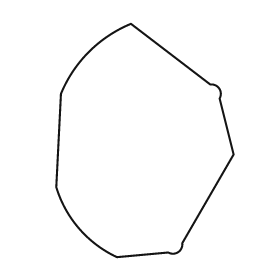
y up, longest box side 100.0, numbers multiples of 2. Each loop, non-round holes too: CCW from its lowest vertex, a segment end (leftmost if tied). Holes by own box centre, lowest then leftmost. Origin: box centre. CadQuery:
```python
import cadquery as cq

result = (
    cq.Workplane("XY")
    .moveTo(-12.0, -50.0)
    .lineTo(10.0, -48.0)
    .threePointArc((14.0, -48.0), (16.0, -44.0))
    .lineTo(38.0, -6.0)
    .lineTo(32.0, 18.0)
    .threePointArc((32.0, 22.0), (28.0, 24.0))
    .lineTo(-6.0, 50.0)
    .threePointArc((-24.0, 38.0), (-36.0, 20.0))
    .lineTo(-38.0, -20.0)
    .threePointArc((-28.0, -38.0), (-12.0, -50.0))
    .close()
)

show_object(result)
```